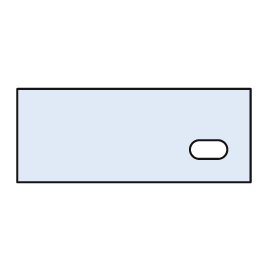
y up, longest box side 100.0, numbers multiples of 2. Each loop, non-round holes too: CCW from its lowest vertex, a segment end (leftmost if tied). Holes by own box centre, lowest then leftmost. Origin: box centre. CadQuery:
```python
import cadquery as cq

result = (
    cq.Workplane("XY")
    .moveTo(-50.0, -20.0)
    .lineTo(50.0, -20.0)
    .lineTo(50.0, 20.0)
    .lineTo(-50.0, 20.0)
    .close()
    .moveTo(28.0, -10.0)
    .lineTo(36.0, -10.0)
    .threePointArc((40.0, -6.0), (36.0, -2.0))
    .lineTo(28.0, -2.0)
    .threePointArc((24.0, -6.0), (28.0, -10.0))
    .close()
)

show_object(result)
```